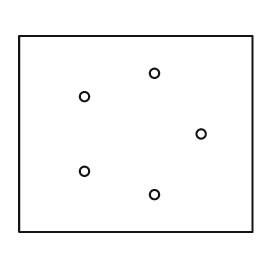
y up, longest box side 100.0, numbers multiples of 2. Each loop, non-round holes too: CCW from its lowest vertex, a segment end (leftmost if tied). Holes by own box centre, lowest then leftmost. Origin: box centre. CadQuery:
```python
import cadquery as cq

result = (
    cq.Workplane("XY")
    .moveTo(-50.0, -42.0)
    .lineTo(50.0, -42.0)
    .lineTo(50.0, 42.0)
    .lineTo(-50.0, 42.0)
    .close()
    .moveTo(8.0, -26.0)
    .circle(2.0)
    .moveTo(-22.0, -16.0)
    .circle(2.0)
    .moveTo(28.0, 0.0)
    .circle(2.0)
    .moveTo(-22.0, 16.0)
    .circle(2.0)
    .moveTo(8.0, 26.0)
    .circle(2.0)
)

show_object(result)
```